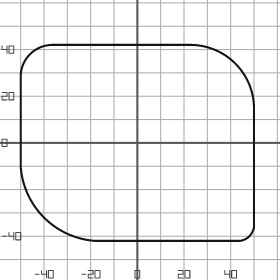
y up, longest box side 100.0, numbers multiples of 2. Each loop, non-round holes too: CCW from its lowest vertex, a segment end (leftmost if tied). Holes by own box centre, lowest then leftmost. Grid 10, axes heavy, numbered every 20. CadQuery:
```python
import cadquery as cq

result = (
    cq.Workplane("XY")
    .moveTo(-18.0, -42.0)
    .lineTo(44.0, -42.0)
    .threePointArc((48.0, -40.0), (50.0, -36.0))
    .lineTo(50.0, 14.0)
    .threePointArc((42.0, 34.0), (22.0, 42.0))
    .lineTo(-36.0, 42.0)
    .threePointArc((-46.0, 38.0), (-50.0, 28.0))
    .lineTo(-50.0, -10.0)
    .threePointArc((-40.0, -32.0), (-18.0, -42.0))
    .close()
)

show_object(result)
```